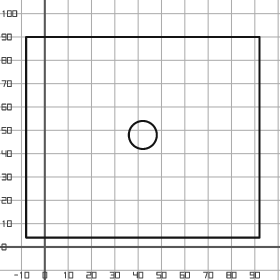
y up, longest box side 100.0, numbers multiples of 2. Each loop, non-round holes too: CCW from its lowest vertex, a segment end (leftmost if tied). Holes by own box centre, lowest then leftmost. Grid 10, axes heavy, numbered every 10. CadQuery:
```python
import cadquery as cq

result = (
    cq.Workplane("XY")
    .moveTo(-8.0, 4.0)
    .lineTo(92.0, 4.0)
    .lineTo(92.0, 90.0)
    .lineTo(-8.0, 90.0)
    .close()
    .moveTo(42.0, 48.0)
    .circle(6.0)
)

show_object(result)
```